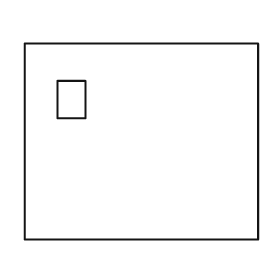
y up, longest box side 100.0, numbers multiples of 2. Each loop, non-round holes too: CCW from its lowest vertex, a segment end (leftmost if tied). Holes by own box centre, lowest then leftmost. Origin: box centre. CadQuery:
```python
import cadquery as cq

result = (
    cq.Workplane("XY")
    .moveTo(-50.0, -42.0)
    .lineTo(50.0, -42.0)
    .lineTo(50.0, 42.0)
    .lineTo(-50.0, 42.0)
    .close()
    .moveTo(-36.0, 10.0)
    .lineTo(-24.0, 10.0)
    .lineTo(-24.0, 26.0)
    .lineTo(-36.0, 26.0)
    .close()
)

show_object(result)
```